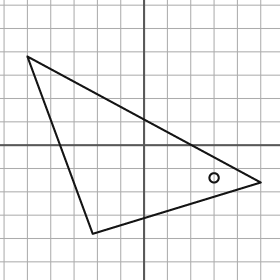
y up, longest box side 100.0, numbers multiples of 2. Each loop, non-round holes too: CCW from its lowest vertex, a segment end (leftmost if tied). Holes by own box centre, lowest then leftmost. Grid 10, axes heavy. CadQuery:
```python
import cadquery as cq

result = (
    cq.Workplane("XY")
    .moveTo(-22.0, -38.0)
    .lineTo(50.0, -16.0)
    .lineTo(-50.0, 38.0)
    .close()
    .moveTo(30.0, -14.0)
    .circle(2.0)
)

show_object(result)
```